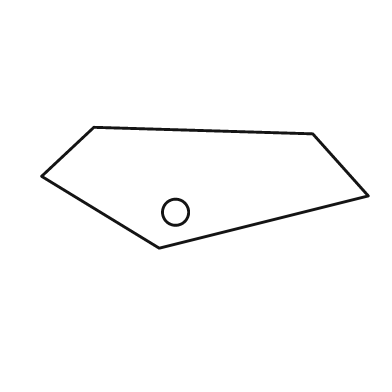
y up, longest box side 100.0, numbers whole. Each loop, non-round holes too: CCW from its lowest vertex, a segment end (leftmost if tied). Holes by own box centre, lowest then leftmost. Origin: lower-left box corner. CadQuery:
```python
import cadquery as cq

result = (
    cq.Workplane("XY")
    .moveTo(36.0, 0.0)
    .lineTo(100.0, 16.0)
    .lineTo(83.0, 35.0)
    .lineTo(16.0, 37.0)
    .lineTo(0.0, 22.0)
    .close()
    .moveTo(41.0, 11.0)
    .circle(4.0)
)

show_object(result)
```